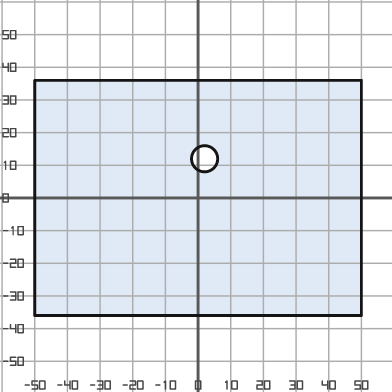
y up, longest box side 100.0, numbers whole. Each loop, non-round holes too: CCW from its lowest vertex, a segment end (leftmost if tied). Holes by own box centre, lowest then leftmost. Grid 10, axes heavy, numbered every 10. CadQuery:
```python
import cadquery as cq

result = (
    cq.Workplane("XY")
    .moveTo(-50.0, -36.0)
    .lineTo(50.0, -36.0)
    .lineTo(50.0, 36.0)
    .lineTo(-50.0, 36.0)
    .close()
    .moveTo(2.0, 12.0)
    .circle(4.0)
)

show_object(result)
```